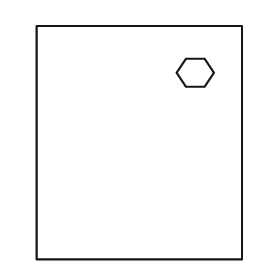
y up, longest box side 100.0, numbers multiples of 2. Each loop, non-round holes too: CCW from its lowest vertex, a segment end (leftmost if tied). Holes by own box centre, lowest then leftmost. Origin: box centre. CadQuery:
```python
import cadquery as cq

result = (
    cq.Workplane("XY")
    .moveTo(-44.0, -50.0)
    .lineTo(44.0, -50.0)
    .lineTo(44.0, 50.0)
    .lineTo(-44.0, 50.0)
    .close()
    .moveTo(20.0, 24.0)
    .lineTo(28.0, 24.0)
    .lineTo(32.0, 30.0)
    .lineTo(28.0, 36.0)
    .lineTo(20.0, 36.0)
    .lineTo(16.0, 30.0)
    .close()
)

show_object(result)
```